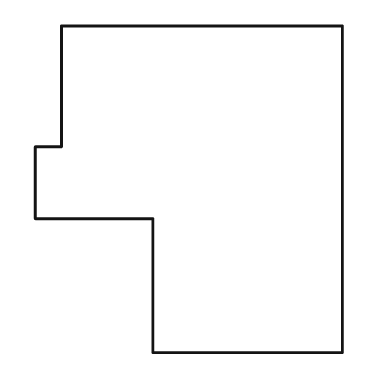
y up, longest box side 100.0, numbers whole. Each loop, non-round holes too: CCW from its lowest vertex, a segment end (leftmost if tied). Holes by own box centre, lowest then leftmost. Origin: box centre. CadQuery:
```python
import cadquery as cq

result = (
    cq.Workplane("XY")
    .moveTo(-11.0, -50.0)
    .lineTo(47.0, -50.0)
    .lineTo(47.0, 50.0)
    .lineTo(-39.0, 50.0)
    .lineTo(-39.0, 13.0)
    .lineTo(-47.0, 13.0)
    .lineTo(-47.0, -9.0)
    .lineTo(-11.0, -9.0)
    .close()
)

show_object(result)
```